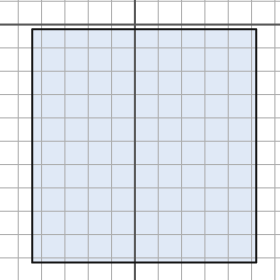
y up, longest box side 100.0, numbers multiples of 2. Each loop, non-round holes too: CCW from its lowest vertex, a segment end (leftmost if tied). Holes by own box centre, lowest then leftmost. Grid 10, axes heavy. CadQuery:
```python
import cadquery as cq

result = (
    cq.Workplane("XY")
    .moveTo(-44.0, -102.0)
    .lineTo(52.0, -102.0)
    .lineTo(52.0, -2.0)
    .lineTo(-44.0, -2.0)
    .close()
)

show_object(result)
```